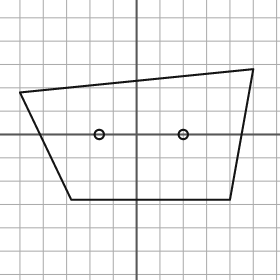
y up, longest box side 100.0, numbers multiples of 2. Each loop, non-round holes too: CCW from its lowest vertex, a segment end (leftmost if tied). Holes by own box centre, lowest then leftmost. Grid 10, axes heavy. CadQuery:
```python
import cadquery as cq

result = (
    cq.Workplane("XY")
    .moveTo(-28.0, -28.0)
    .lineTo(40.0, -28.0)
    .lineTo(50.0, 28.0)
    .lineTo(-50.0, 18.0)
    .close()
    .moveTo(-16.0, 0.0)
    .circle(2.0)
    .moveTo(20.0, 0.0)
    .circle(2.0)
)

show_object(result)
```